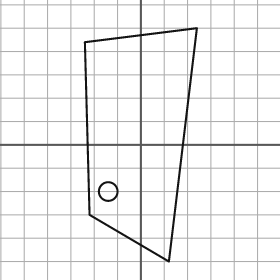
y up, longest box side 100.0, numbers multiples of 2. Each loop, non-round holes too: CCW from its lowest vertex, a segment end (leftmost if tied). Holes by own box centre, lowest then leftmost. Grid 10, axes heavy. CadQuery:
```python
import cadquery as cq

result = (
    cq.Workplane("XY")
    .moveTo(12.0, -50.0)
    .lineTo(24.0, 50.0)
    .lineTo(-24.0, 44.0)
    .lineTo(-22.0, -30.0)
    .close()
    .moveTo(-14.0, -20.0)
    .circle(4.0)
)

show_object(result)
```